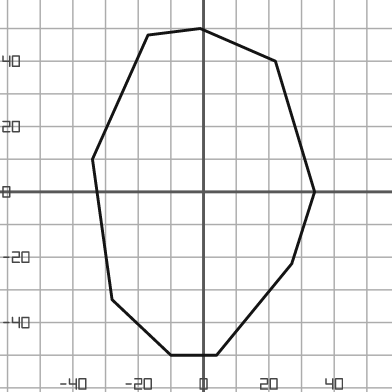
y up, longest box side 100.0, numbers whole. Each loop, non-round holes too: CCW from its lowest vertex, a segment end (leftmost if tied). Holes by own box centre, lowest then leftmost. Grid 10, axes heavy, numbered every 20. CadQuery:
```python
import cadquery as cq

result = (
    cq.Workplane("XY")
    .moveTo(-10.0, -50.0)
    .lineTo(4.0, -50.0)
    .lineTo(27.0, -22.0)
    .lineTo(34.0, 0.0)
    .lineTo(22.0, 40.0)
    .lineTo(-1.0, 50.0)
    .lineTo(-17.0, 48.0)
    .lineTo(-34.0, 10.0)
    .lineTo(-28.0, -33.0)
    .close()
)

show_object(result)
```